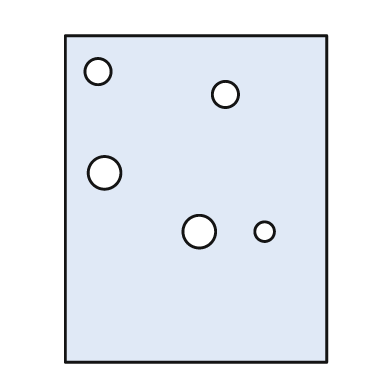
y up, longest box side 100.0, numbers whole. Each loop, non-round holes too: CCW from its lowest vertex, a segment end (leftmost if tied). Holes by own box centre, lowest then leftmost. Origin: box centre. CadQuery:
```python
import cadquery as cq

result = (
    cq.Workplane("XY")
    .moveTo(-40.0, -50.0)
    .lineTo(40.0, -50.0)
    .lineTo(40.0, 50.0)
    .lineTo(-40.0, 50.0)
    .close()
    .moveTo(1.0, -10.0)
    .circle(5.0)
    .moveTo(21.0, -10.0)
    .circle(3.0)
    .moveTo(-28.0, 8.0)
    .circle(5.0)
    .moveTo(9.0, 32.0)
    .circle(4.0)
    .moveTo(-30.0, 39.0)
    .circle(4.0)
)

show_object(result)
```